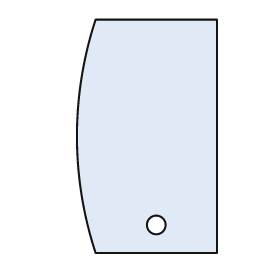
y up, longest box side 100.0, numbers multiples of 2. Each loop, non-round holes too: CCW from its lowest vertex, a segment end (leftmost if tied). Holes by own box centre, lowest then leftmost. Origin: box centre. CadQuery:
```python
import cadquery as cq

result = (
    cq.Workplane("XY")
    .moveTo(-22.0, -50.0)
    .lineTo(30.0, -50.0)
    .lineTo(30.0, 50.0)
    .lineTo(-22.0, 50.0)
    .threePointArc((-30.0, 0.0), (-22.0, -50.0))
    .close()
    .moveTo(4.0, -38.0)
    .circle(4.0)
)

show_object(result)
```